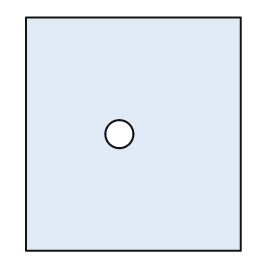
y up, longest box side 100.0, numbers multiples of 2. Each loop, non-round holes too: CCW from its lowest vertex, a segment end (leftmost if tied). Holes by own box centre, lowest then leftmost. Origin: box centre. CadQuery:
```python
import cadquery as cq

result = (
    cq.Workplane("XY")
    .moveTo(-46.0, -50.0)
    .lineTo(46.0, -50.0)
    .lineTo(46.0, 50.0)
    .lineTo(-46.0, 50.0)
    .close()
    .moveTo(-6.0, 0.0)
    .circle(6.0)
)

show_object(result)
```